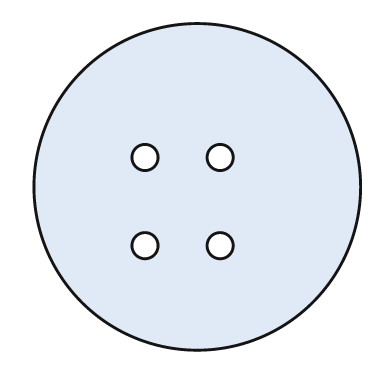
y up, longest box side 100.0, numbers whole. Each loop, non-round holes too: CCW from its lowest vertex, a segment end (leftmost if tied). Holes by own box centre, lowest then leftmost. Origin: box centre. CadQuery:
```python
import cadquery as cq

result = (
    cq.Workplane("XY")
    .moveTo(0.0, 0.0)
    .circle(50.0)
    .moveTo(-16.0, -18.0)
    .circle(4.0)
    .moveTo(7.0, -18.0)
    .circle(4.0)
    .moveTo(-16.0, 9.0)
    .circle(4.0)
    .moveTo(7.0, 9.0)
    .circle(4.0)
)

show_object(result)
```